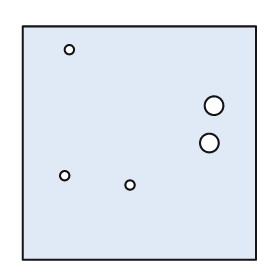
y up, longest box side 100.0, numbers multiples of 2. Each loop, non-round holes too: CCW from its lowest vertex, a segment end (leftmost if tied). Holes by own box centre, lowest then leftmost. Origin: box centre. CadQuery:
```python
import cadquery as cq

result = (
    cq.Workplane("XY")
    .moveTo(-50.0, -50.0)
    .lineTo(50.0, -50.0)
    .lineTo(50.0, 50.0)
    .lineTo(-50.0, 50.0)
    .close()
    .moveTo(-4.0, -18.0)
    .circle(2.0)
    .moveTo(-32.0, -14.0)
    .circle(2.0)
    .moveTo(30.0, 0.0)
    .circle(4.0)
    .moveTo(32.0, 16.0)
    .circle(4.0)
    .moveTo(-30.0, 40.0)
    .circle(2.0)
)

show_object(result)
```